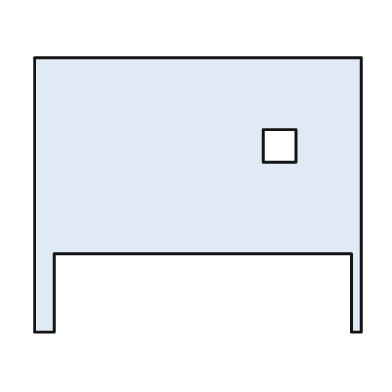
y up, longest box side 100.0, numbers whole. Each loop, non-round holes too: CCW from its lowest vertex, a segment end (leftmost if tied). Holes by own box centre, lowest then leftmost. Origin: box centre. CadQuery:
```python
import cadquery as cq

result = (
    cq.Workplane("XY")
    .moveTo(-50.0, -42.0)
    .lineTo(-44.0, -42.0)
    .lineTo(-44.0, -18.0)
    .lineTo(47.0, -18.0)
    .lineTo(47.0, -42.0)
    .lineTo(50.0, -42.0)
    .lineTo(50.0, 42.0)
    .lineTo(-50.0, 42.0)
    .close()
    .moveTo(20.0, 10.0)
    .lineTo(30.0, 10.0)
    .lineTo(30.0, 20.0)
    .lineTo(20.0, 20.0)
    .close()
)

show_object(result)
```